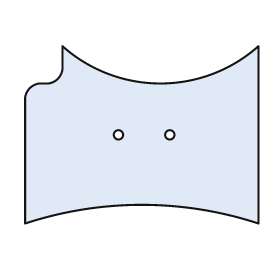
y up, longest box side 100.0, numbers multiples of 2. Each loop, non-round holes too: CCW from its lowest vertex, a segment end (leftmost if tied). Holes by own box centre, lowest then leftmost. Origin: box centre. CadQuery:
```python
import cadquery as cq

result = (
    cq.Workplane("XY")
    .moveTo(-50.0, -38.0)
    .threePointArc((0.0, -30.0), (50.0, -38.0))
    .lineTo(50.0, 38.0)
    .threePointArc((8.0, 22.0), (-34.0, 38.0))
    .lineTo(-34.0, 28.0)
    .threePointArc((-36.0, 24.0), (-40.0, 22.0))
    .lineTo(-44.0, 22.0)
    .threePointArc((-48.0, 20.0), (-50.0, 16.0))
    .close()
    .moveTo(-10.0, 0.0)
    .circle(2.0)
    .moveTo(12.0, 0.0)
    .circle(2.0)
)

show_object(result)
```